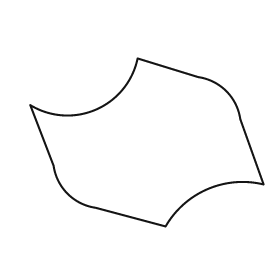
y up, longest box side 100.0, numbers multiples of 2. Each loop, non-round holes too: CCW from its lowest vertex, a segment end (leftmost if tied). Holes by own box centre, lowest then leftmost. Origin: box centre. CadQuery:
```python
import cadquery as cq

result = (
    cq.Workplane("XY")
    .moveTo(8.0, -36.0)
    .threePointArc((26.0, -20.0), (50.0, -18.0))
    .lineTo(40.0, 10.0)
    .threePointArc((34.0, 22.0), (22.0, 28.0))
    .lineTo(-4.0, 36.0)
    .threePointArc((-22.0, 14.0), (-50.0, 16.0))
    .lineTo(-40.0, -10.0)
    .threePointArc((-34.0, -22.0), (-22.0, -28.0))
    .close()
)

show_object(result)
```